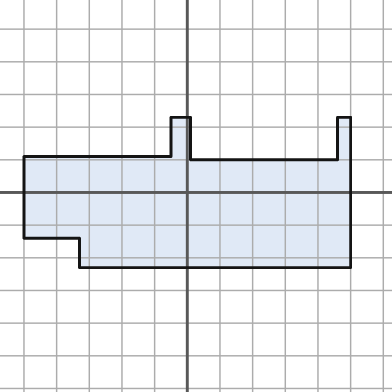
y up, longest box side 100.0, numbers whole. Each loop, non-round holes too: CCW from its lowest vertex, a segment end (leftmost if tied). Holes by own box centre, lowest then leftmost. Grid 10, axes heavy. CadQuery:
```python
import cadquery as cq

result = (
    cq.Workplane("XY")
    .moveTo(-33.0, -23.0)
    .lineTo(50.0, -23.0)
    .lineTo(50.0, 23.0)
    .lineTo(46.0, 23.0)
    .lineTo(46.0, 10.0)
    .lineTo(1.0, 10.0)
    .lineTo(1.0, 23.0)
    .lineTo(-5.0, 23.0)
    .lineTo(-5.0, 11.0)
    .lineTo(-50.0, 11.0)
    .lineTo(-50.0, -14.0)
    .lineTo(-33.0, -14.0)
    .close()
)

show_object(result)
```